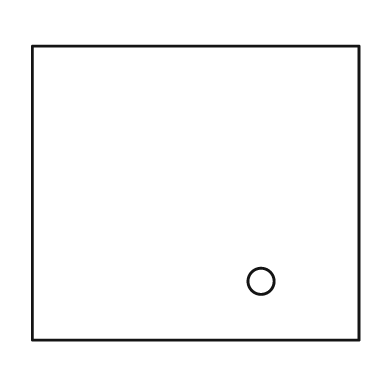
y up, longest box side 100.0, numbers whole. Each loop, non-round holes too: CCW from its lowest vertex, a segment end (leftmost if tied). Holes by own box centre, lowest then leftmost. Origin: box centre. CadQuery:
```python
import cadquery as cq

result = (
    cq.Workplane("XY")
    .moveTo(-50.0, -45.0)
    .lineTo(50.0, -45.0)
    .lineTo(50.0, 45.0)
    .lineTo(-50.0, 45.0)
    .close()
    .moveTo(20.0, -27.0)
    .circle(4.0)
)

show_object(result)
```